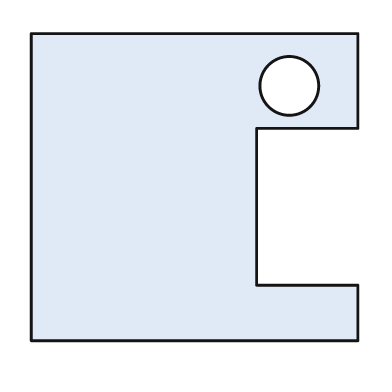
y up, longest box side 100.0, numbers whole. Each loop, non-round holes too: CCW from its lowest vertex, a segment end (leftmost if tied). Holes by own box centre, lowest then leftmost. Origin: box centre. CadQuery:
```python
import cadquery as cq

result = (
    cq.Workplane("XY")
    .moveTo(-50.0, -47.0)
    .lineTo(50.0, -47.0)
    .lineTo(50.0, -30.0)
    .lineTo(19.0, -30.0)
    .lineTo(19.0, 18.0)
    .lineTo(50.0, 18.0)
    .lineTo(50.0, 47.0)
    .lineTo(-50.0, 47.0)
    .close()
    .moveTo(29.0, 31.0)
    .circle(9.0)
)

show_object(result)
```